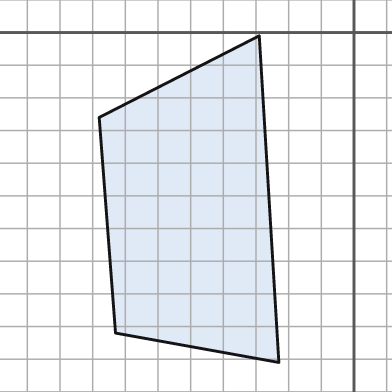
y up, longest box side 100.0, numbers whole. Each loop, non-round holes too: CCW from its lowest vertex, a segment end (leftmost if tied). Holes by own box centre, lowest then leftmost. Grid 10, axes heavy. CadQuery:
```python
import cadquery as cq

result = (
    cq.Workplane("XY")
    .moveTo(-23.0, -101.0)
    .lineTo(-29.0, -1.0)
    .lineTo(-78.0, -26.0)
    .lineTo(-73.0, -92.0)
    .close()
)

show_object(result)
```